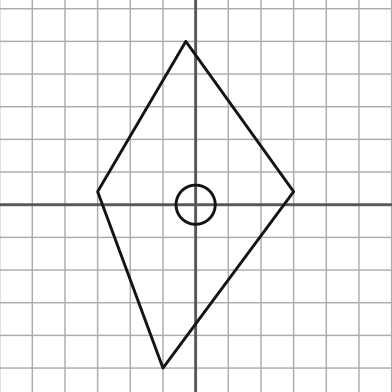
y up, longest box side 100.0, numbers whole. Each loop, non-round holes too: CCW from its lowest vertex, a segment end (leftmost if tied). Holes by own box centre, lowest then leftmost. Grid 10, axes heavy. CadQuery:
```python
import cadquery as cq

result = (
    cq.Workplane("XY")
    .moveTo(-10.0, -50.0)
    .lineTo(30.0, 4.0)
    .lineTo(-3.0, 50.0)
    .lineTo(-30.0, 4.0)
    .close()
    .moveTo(0.0, 0.0)
    .circle(6.0)
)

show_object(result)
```